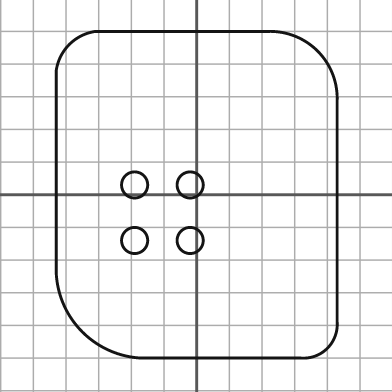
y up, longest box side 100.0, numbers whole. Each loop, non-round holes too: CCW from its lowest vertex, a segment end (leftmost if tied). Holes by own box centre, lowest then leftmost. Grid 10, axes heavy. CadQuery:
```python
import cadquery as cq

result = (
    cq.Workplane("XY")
    .moveTo(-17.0, -50.0)
    .lineTo(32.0, -50.0)
    .threePointArc((40.0, -47.0), (43.0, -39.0))
    .lineTo(43.0, 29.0)
    .threePointArc((37.0, 44.0), (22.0, 50.0))
    .lineTo(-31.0, 50.0)
    .threePointArc((-39.0, 46.0), (-43.0, 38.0))
    .lineTo(-43.0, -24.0)
    .threePointArc((-35.0, -42.0), (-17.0, -50.0))
    .close()
    .moveTo(-19.0, -14.0)
    .circle(4.0)
    .moveTo(-2.0, -14.0)
    .circle(4.0)
    .moveTo(-19.0, 3.0)
    .circle(4.0)
    .moveTo(-2.0, 3.0)
    .circle(4.0)
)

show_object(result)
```